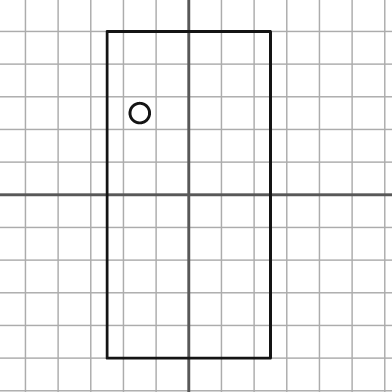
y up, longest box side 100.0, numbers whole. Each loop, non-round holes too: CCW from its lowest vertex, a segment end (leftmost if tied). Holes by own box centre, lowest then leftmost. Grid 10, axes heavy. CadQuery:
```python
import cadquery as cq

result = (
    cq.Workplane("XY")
    .moveTo(-25.0, -50.0)
    .lineTo(25.0, -50.0)
    .lineTo(25.0, 50.0)
    .lineTo(-25.0, 50.0)
    .close()
    .moveTo(-15.0, 25.0)
    .circle(3.0)
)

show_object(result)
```